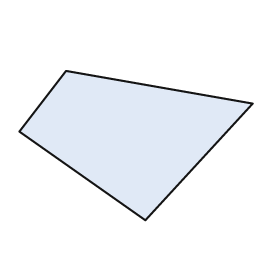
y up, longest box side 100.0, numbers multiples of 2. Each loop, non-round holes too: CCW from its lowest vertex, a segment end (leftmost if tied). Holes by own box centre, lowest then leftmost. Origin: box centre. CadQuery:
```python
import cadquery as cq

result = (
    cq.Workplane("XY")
    .moveTo(4.0, -32.0)
    .lineTo(50.0, 18.0)
    .lineTo(-30.0, 32.0)
    .lineTo(-50.0, 6.0)
    .close()
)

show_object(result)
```